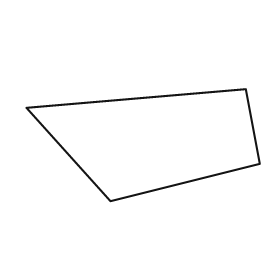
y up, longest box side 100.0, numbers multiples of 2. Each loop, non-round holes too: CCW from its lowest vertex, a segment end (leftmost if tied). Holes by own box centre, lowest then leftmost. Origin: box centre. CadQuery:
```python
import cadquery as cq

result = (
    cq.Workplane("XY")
    .moveTo(-14.0, -24.0)
    .lineTo(50.0, -8.0)
    .lineTo(44.0, 24.0)
    .lineTo(-50.0, 16.0)
    .close()
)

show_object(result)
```